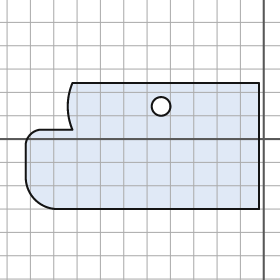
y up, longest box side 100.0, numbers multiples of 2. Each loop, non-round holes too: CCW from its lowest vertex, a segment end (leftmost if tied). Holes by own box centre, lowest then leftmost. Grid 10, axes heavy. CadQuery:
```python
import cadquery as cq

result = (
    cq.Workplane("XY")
    .moveTo(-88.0, -30.0)
    .lineTo(-2.0, -30.0)
    .lineTo(-2.0, 24.0)
    .lineTo(-82.0, 24.0)
    .threePointArc((-84.0, 14.0), (-82.0, 4.0))
    .lineTo(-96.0, 4.0)
    .threePointArc((-100.0, 2.0), (-102.0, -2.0))
    .lineTo(-102.0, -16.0)
    .threePointArc((-98.0, -26.0), (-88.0, -30.0))
    .close()
    .moveTo(-44.0, 14.0)
    .circle(4.0)
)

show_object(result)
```